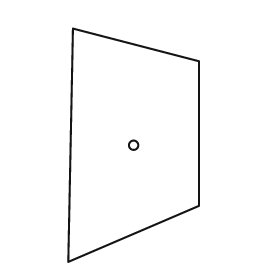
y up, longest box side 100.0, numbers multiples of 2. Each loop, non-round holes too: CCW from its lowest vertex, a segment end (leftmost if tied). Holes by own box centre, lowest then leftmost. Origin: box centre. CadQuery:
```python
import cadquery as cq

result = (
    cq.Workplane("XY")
    .moveTo(-28.0, -50.0)
    .lineTo(28.0, -26.0)
    .lineTo(28.0, 36.0)
    .lineTo(-26.0, 50.0)
    .close()
    .moveTo(0.0, 0.0)
    .circle(2.0)
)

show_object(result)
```